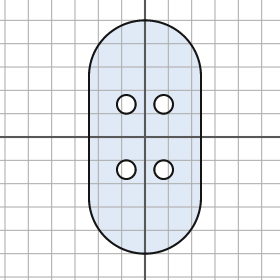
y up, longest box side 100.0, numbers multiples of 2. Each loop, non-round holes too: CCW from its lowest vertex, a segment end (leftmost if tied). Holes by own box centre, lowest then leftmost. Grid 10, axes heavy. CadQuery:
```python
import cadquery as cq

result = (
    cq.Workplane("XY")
    .moveTo(-24.0, -26.0)
    .threePointArc((0.0, -50.0), (24.0, -26.0))
    .lineTo(24.0, 26.0)
    .threePointArc((0.0, 50.0), (-24.0, 26.0))
    .close()
    .moveTo(-8.0, -14.0)
    .circle(4.0)
    .moveTo(8.0, -14.0)
    .circle(4.0)
    .moveTo(-8.0, 14.0)
    .circle(4.0)
    .moveTo(8.0, 14.0)
    .circle(4.0)
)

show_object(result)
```